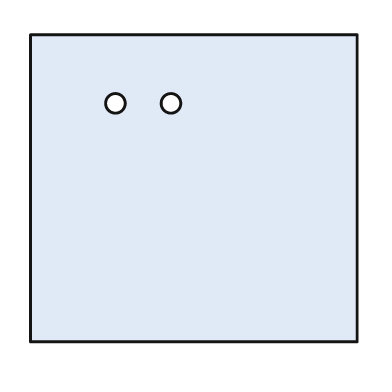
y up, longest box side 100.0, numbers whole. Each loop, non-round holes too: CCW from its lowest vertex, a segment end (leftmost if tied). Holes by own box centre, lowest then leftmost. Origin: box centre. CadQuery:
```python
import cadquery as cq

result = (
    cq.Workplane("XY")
    .moveTo(-50.0, -47.0)
    .lineTo(50.0, -47.0)
    .lineTo(50.0, 47.0)
    .lineTo(-50.0, 47.0)
    .close()
    .moveTo(-24.0, 26.0)
    .circle(3.0)
    .moveTo(-7.0, 26.0)
    .circle(3.0)
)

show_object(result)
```